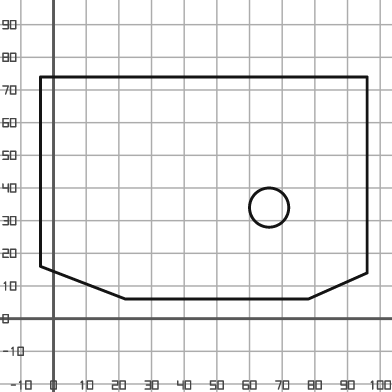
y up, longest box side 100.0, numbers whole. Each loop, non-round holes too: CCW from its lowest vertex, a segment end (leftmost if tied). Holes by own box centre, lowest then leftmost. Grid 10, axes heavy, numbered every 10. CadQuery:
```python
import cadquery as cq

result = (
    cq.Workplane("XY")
    .moveTo(22.0, 6.0)
    .lineTo(78.0, 6.0)
    .lineTo(96.0, 14.0)
    .lineTo(96.0, 74.0)
    .lineTo(-4.0, 74.0)
    .lineTo(-4.0, 16.0)
    .close()
    .moveTo(66.0, 34.0)
    .circle(6.0)
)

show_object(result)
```